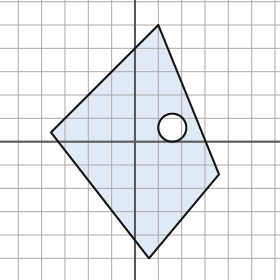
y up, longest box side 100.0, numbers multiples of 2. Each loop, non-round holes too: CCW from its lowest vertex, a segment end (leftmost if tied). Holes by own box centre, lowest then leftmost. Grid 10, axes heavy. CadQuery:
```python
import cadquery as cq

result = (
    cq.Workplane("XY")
    .moveTo(6.0, -50.0)
    .lineTo(36.0, -14.0)
    .lineTo(10.0, 50.0)
    .lineTo(-36.0, 4.0)
    .close()
    .moveTo(16.0, 6.0)
    .circle(6.0)
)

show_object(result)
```